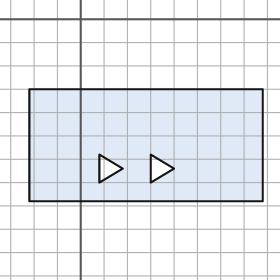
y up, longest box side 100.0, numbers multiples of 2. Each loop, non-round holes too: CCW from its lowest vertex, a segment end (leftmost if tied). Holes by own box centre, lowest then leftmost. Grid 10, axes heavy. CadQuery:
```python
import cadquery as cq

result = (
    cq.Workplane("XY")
    .moveTo(-22.0, -78.0)
    .lineTo(78.0, -78.0)
    .lineTo(78.0, -30.0)
    .lineTo(-22.0, -30.0)
    .close()
    .moveTo(8.0, -70.0)
    .lineTo(18.0, -64.0)
    .lineTo(8.0, -58.0)
    .close()
    .moveTo(30.0, -70.0)
    .lineTo(40.0, -64.0)
    .lineTo(30.0, -58.0)
    .close()
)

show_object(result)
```